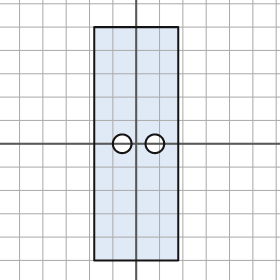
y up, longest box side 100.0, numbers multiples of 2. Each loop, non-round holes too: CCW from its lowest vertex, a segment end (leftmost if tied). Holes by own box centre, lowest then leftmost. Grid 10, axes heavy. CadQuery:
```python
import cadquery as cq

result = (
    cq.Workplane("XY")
    .moveTo(-18.0, -50.0)
    .lineTo(18.0, -50.0)
    .lineTo(18.0, 50.0)
    .lineTo(-18.0, 50.0)
    .close()
    .moveTo(-6.0, 0.0)
    .circle(4.0)
    .moveTo(8.0, 0.0)
    .circle(4.0)
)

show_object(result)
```